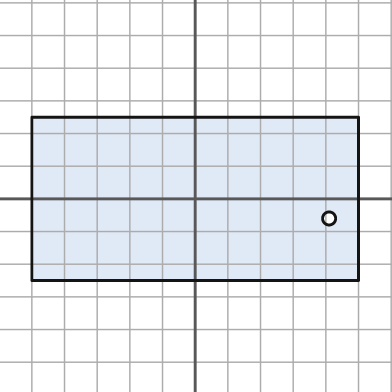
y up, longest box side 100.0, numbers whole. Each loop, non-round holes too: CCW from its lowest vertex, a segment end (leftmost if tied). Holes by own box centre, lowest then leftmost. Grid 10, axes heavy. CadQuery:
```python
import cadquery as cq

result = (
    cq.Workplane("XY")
    .moveTo(-50.0, -25.0)
    .lineTo(50.0, -25.0)
    .lineTo(50.0, 25.0)
    .lineTo(-50.0, 25.0)
    .close()
    .moveTo(41.0, -6.0)
    .circle(2.0)
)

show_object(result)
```